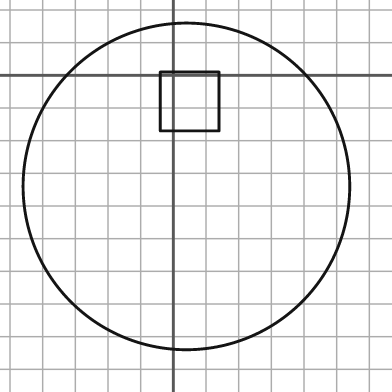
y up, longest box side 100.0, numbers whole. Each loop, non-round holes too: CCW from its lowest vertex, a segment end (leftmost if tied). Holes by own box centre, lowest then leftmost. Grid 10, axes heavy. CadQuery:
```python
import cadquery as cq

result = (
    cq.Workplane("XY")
    .moveTo(4.0, -34.0)
    .circle(50.0)
    .moveTo(-4.0, -17.0)
    .lineTo(14.0, -17.0)
    .lineTo(14.0, 1.0)
    .lineTo(-4.0, 1.0)
    .close()
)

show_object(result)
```